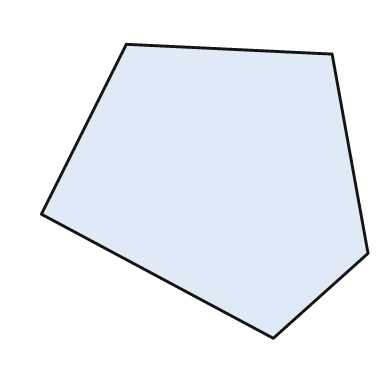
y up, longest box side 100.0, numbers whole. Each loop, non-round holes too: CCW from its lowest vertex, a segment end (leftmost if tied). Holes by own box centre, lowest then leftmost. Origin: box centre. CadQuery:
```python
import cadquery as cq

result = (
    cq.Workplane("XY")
    .moveTo(21.0, -45.0)
    .lineTo(50.0, -19.0)
    .lineTo(39.0, 42.0)
    .lineTo(-24.0, 45.0)
    .lineTo(-50.0, -7.0)
    .close()
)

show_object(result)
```